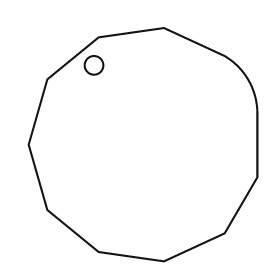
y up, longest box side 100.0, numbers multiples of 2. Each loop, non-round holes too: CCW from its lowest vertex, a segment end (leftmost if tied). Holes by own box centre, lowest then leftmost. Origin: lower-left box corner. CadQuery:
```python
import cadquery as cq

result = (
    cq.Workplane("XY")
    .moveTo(58.0, 0.0)
    .lineTo(84.0, 12.0)
    .lineTo(98.0, 36.0)
    .lineTo(98.0, 64.0)
    .threePointArc((94.0, 78.0), (84.0, 88.0))
    .lineTo(58.0, 100.0)
    .lineTo(30.0, 96.0)
    .lineTo(8.0, 78.0)
    .lineTo(0.0, 50.0)
    .lineTo(8.0, 22.0)
    .lineTo(30.0, 4.0)
    .close()
    .moveTo(28.0, 84.0)
    .circle(4.0)
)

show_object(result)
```